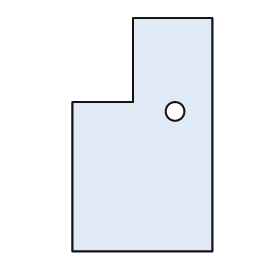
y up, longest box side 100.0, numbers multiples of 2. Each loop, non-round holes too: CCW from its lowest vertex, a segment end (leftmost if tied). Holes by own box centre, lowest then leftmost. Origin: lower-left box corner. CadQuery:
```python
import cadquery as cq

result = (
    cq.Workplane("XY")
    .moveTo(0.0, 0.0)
    .lineTo(60.0, 0.0)
    .lineTo(60.0, 100.0)
    .lineTo(26.0, 100.0)
    .lineTo(26.0, 64.0)
    .lineTo(0.0, 64.0)
    .close()
    .moveTo(44.0, 60.0)
    .circle(4.0)
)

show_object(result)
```